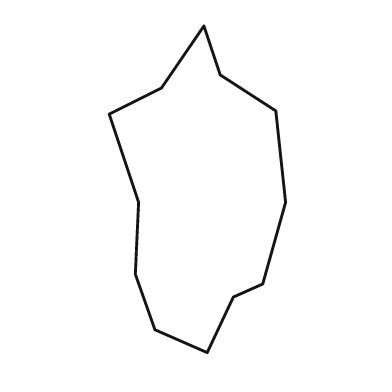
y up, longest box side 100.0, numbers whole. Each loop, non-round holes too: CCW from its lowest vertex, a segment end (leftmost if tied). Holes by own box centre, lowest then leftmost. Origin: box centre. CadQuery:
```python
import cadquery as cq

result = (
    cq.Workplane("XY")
    .moveTo(3.0, -50.0)
    .lineTo(11.0, -33.0)
    .lineTo(20.0, -29.0)
    .lineTo(27.0, -4.0)
    .lineTo(24.0, 24.0)
    .lineTo(7.0, 35.0)
    .lineTo(2.0, 50.0)
    .lineTo(-11.0, 31.0)
    .lineTo(-27.0, 23.0)
    .lineTo(-18.0, -4.0)
    .lineTo(-19.0, -26.0)
    .lineTo(-13.0, -43.0)
    .close()
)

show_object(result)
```